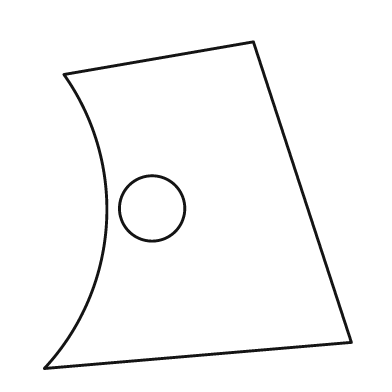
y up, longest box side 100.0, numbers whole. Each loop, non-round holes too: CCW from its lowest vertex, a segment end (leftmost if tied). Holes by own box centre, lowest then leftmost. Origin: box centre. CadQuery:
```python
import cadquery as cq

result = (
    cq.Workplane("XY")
    .moveTo(-47.0, -50.0)
    .lineTo(47.0, -42.0)
    .lineTo(17.0, 50.0)
    .lineTo(-41.0, 40.0)
    .threePointArc((-28.0, -6.0), (-47.0, -50.0))
    .close()
    .moveTo(-14.0, -1.0)
    .circle(10.0)
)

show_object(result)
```